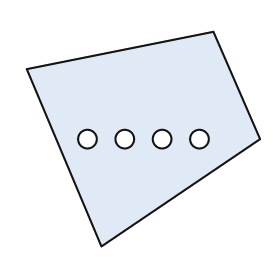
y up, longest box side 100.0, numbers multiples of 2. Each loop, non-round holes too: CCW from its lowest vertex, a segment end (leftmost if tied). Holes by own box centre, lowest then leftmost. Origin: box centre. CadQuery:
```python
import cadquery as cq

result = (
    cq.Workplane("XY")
    .moveTo(-18.0, -46.0)
    .lineTo(50.0, 0.0)
    .lineTo(30.0, 46.0)
    .lineTo(-50.0, 30.0)
    .close()
    .moveTo(-24.0, 0.0)
    .circle(4.0)
    .moveTo(-8.0, 0.0)
    .circle(4.0)
    .moveTo(8.0, 0.0)
    .circle(4.0)
    .moveTo(24.0, 0.0)
    .circle(4.0)
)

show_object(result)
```